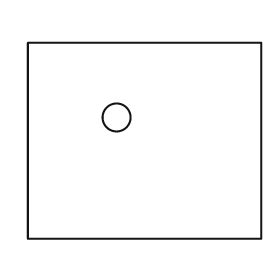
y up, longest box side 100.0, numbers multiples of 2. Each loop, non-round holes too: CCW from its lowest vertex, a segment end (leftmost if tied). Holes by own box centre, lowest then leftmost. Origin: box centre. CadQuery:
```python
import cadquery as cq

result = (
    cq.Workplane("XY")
    .moveTo(-50.0, -42.0)
    .lineTo(50.0, -42.0)
    .lineTo(50.0, 42.0)
    .lineTo(-50.0, 42.0)
    .close()
    .moveTo(-12.0, 10.0)
    .circle(6.0)
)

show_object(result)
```